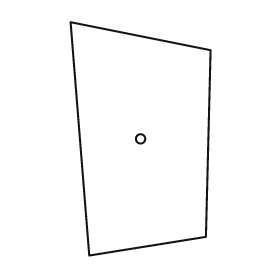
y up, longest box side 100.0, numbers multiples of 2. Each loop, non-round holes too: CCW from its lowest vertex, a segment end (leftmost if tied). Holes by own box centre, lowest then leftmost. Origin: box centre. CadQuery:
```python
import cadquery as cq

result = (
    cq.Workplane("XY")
    .moveTo(-22.0, -50.0)
    .lineTo(28.0, -42.0)
    .lineTo(30.0, 38.0)
    .lineTo(-30.0, 50.0)
    .close()
    .moveTo(0.0, 0.0)
    .circle(2.0)
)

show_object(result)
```